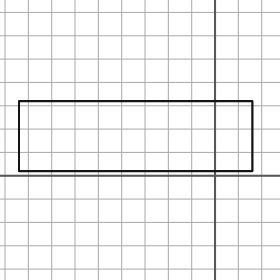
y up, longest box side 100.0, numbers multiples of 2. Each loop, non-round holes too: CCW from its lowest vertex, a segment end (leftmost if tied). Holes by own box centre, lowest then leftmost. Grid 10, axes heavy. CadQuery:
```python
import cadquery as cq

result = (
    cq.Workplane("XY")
    .moveTo(-84.0, 2.0)
    .lineTo(16.0, 2.0)
    .lineTo(16.0, 32.0)
    .lineTo(-84.0, 32.0)
    .close()
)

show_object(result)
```